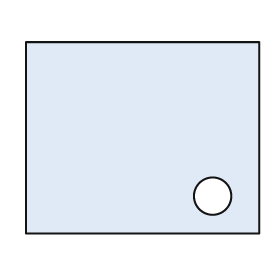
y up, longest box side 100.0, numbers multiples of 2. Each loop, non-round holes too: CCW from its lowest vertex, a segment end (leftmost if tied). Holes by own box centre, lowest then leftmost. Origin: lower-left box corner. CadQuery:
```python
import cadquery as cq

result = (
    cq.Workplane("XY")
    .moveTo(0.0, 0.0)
    .lineTo(100.0, 0.0)
    .lineTo(100.0, 82.0)
    .lineTo(0.0, 82.0)
    .close()
    .moveTo(80.0, 16.0)
    .circle(8.0)
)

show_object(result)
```